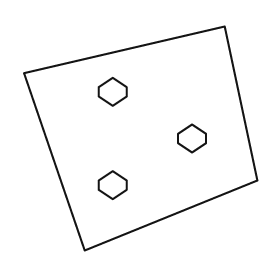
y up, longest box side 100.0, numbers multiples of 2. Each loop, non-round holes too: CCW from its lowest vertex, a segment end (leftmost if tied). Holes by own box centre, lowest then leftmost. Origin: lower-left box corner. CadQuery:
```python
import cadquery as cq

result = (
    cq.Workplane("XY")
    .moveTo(26.0, 0.0)
    .lineTo(100.0, 30.0)
    .lineTo(86.0, 96.0)
    .lineTo(0.0, 76.0)
    .close()
    .moveTo(38.0, 22.0)
    .lineTo(44.0, 26.0)
    .lineTo(44.0, 30.0)
    .lineTo(38.0, 34.0)
    .lineTo(32.0, 30.0)
    .lineTo(32.0, 26.0)
    .close()
    .moveTo(72.0, 42.0)
    .lineTo(78.0, 46.0)
    .lineTo(78.0, 50.0)
    .lineTo(72.0, 54.0)
    .lineTo(66.0, 50.0)
    .lineTo(66.0, 46.0)
    .close()
    .moveTo(38.0, 62.0)
    .lineTo(44.0, 66.0)
    .lineTo(44.0, 70.0)
    .lineTo(38.0, 74.0)
    .lineTo(32.0, 70.0)
    .lineTo(32.0, 66.0)
    .close()
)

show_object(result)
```